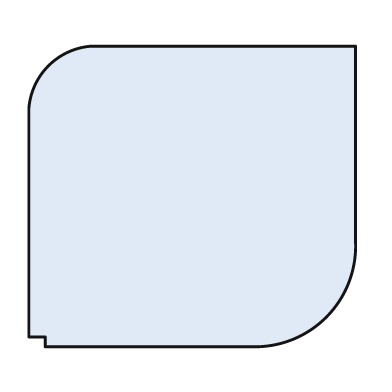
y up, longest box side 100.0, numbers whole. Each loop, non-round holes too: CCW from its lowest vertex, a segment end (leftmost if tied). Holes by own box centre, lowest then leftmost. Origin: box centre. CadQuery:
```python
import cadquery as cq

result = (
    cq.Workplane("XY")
    .moveTo(-45.0, -46.0)
    .lineTo(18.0, -46.0)
    .threePointArc((41.0, -37.0), (50.0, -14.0))
    .lineTo(50.0, 46.0)
    .lineTo(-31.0, 46.0)
    .threePointArc((-44.0, 40.0), (-50.0, 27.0))
    .lineTo(-50.0, -43.0)
    .lineTo(-45.0, -43.0)
    .close()
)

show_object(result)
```